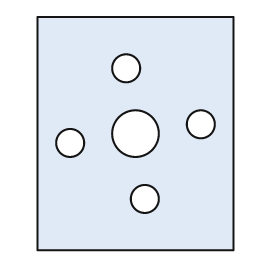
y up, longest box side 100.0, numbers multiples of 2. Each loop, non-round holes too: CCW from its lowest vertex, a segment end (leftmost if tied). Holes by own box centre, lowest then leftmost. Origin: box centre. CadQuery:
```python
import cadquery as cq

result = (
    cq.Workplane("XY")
    .moveTo(-42.0, -50.0)
    .lineTo(42.0, -50.0)
    .lineTo(42.0, 50.0)
    .lineTo(-42.0, 50.0)
    .close()
    .moveTo(4.0, -28.0)
    .circle(6.0)
    .moveTo(-28.0, -4.0)
    .circle(6.0)
    .moveTo(0.0, 0.0)
    .circle(10.0)
    .moveTo(28.0, 4.0)
    .circle(6.0)
    .moveTo(-4.0, 28.0)
    .circle(6.0)
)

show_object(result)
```